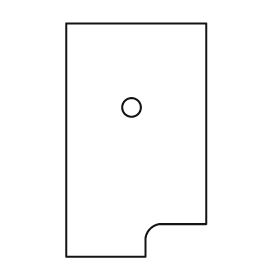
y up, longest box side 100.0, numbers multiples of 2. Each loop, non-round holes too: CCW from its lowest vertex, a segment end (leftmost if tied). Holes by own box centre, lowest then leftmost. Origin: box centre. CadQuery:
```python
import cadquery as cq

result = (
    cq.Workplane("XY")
    .moveTo(-30.0, -50.0)
    .lineTo(4.0, -50.0)
    .lineTo(4.0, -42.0)
    .threePointArc((6.0, -38.0), (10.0, -36.0))
    .lineTo(30.0, -36.0)
    .lineTo(30.0, 50.0)
    .lineTo(-30.0, 50.0)
    .close()
    .moveTo(-2.0, 14.0)
    .circle(4.0)
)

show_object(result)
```